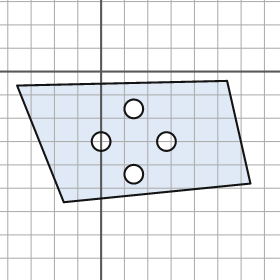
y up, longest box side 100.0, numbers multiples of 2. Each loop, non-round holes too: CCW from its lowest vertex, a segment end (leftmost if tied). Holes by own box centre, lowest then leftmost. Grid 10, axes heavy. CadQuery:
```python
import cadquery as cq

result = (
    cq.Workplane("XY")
    .moveTo(-16.0, -56.0)
    .lineTo(64.0, -48.0)
    .lineTo(54.0, -4.0)
    .lineTo(-36.0, -6.0)
    .close()
    .moveTo(14.0, -44.0)
    .circle(4.0)
    .moveTo(0.0, -30.0)
    .circle(4.0)
    .moveTo(28.0, -30.0)
    .circle(4.0)
    .moveTo(14.0, -16.0)
    .circle(4.0)
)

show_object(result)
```